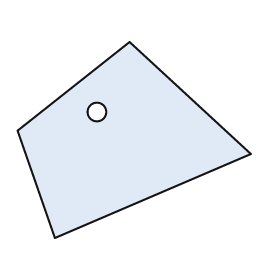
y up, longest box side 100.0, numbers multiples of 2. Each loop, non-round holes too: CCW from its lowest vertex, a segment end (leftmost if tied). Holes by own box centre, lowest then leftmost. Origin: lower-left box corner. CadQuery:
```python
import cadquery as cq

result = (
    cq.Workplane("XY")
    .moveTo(16.0, 0.0)
    .lineTo(100.0, 36.0)
    .lineTo(48.0, 84.0)
    .lineTo(0.0, 46.0)
    .close()
    .moveTo(34.0, 54.0)
    .circle(4.0)
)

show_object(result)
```